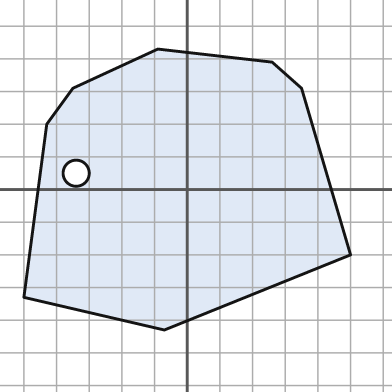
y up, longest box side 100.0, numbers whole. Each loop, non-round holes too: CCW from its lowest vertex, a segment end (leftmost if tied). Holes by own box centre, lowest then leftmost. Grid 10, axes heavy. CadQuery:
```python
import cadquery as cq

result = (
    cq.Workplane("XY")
    .moveTo(-7.0, -43.0)
    .lineTo(50.0, -20.0)
    .lineTo(35.0, 31.0)
    .lineTo(26.0, 39.0)
    .lineTo(-9.0, 43.0)
    .lineTo(-35.0, 31.0)
    .lineTo(-43.0, 20.0)
    .lineTo(-50.0, -33.0)
    .close()
    .moveTo(-34.0, 5.0)
    .circle(4.0)
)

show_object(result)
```